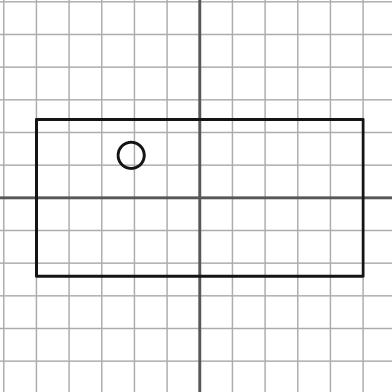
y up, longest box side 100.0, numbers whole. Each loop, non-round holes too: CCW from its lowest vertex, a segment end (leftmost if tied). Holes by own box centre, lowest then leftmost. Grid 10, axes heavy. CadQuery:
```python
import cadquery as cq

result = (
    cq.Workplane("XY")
    .moveTo(-50.0, -24.0)
    .lineTo(50.0, -24.0)
    .lineTo(50.0, 24.0)
    .lineTo(-50.0, 24.0)
    .close()
    .moveTo(-21.0, 13.0)
    .circle(4.0)
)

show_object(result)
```